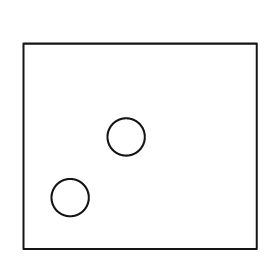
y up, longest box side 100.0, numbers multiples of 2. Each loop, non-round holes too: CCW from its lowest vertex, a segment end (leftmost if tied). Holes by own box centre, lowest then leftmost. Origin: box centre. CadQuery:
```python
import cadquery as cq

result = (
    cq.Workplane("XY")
    .moveTo(-50.0, -44.0)
    .lineTo(50.0, -44.0)
    .lineTo(50.0, 44.0)
    .lineTo(-50.0, 44.0)
    .close()
    .moveTo(-30.0, -22.0)
    .circle(8.0)
    .moveTo(-6.0, 4.0)
    .circle(8.0)
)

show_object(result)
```